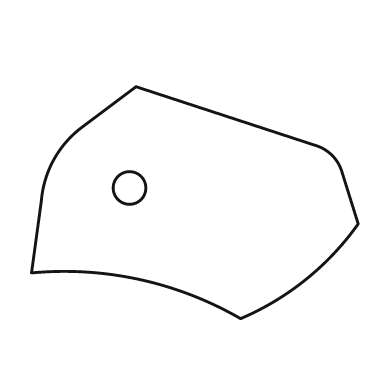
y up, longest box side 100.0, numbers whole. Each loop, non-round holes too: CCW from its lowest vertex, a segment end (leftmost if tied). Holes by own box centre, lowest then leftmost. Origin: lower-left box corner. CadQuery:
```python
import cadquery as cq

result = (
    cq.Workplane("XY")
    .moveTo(64.0, 0.0)
    .threePointArc((84.0, 12.0), (100.0, 29.0))
    .lineTo(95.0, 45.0)
    .threePointArc((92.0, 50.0), (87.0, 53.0))
    .lineTo(32.0, 71.0)
    .lineTo(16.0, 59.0)
    .threePointArc((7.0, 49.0), (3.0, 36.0))
    .lineTo(0.0, 14.0)
    .threePointArc((33.0, 12.0), (64.0, 0.0))
    .close()
    .moveTo(30.0, 40.0)
    .circle(5.0)
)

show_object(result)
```